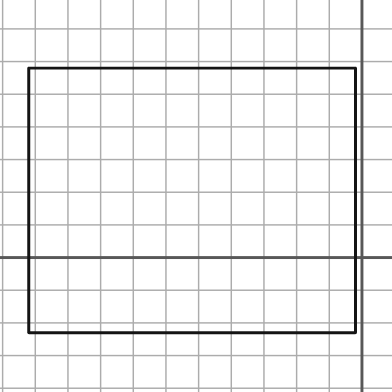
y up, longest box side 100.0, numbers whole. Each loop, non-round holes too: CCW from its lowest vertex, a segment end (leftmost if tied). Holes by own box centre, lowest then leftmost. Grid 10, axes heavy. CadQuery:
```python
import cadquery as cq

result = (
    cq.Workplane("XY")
    .moveTo(-102.0, -23.0)
    .lineTo(-2.0, -23.0)
    .lineTo(-2.0, 58.0)
    .lineTo(-102.0, 58.0)
    .close()
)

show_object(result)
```